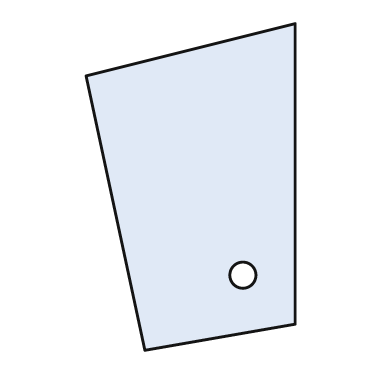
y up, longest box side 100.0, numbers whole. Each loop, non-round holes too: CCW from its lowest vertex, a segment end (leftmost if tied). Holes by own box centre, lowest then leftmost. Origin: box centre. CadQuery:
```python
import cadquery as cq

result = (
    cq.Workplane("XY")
    .moveTo(-14.0, -50.0)
    .lineTo(32.0, -42.0)
    .lineTo(32.0, 50.0)
    .lineTo(-32.0, 34.0)
    .close()
    .moveTo(16.0, -27.0)
    .circle(4.0)
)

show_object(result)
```